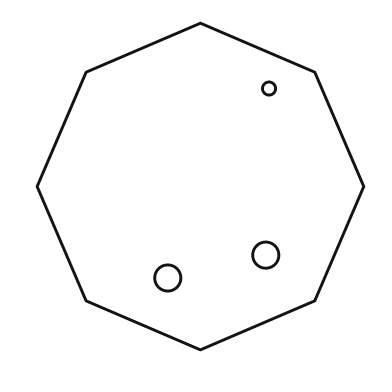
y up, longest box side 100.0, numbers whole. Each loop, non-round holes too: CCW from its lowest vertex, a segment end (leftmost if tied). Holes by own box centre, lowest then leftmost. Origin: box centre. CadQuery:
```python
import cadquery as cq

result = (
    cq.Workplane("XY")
    .moveTo(0.0, -50.0)
    .lineTo(35.0, -35.0)
    .lineTo(50.0, 0.0)
    .lineTo(35.0, 35.0)
    .lineTo(0.0, 50.0)
    .lineTo(-35.0, 35.0)
    .lineTo(-50.0, 0.0)
    .lineTo(-35.0, -35.0)
    .close()
    .moveTo(-10.0, -28.0)
    .circle(4.0)
    .moveTo(20.0, -21.0)
    .circle(4.0)
    .moveTo(21.0, 30.0)
    .circle(2.0)
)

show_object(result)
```